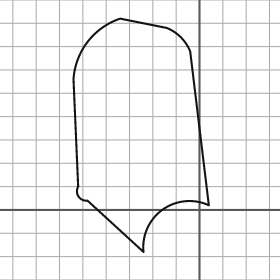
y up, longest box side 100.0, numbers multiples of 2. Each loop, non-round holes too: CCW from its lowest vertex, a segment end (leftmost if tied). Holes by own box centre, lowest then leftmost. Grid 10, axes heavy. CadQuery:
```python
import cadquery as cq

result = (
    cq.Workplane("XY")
    .moveTo(-24.0, -18.0)
    .threePointArc((-16.0, 0.0), (4.0, 2.0))
    .lineTo(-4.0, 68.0)
    .threePointArc((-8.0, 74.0), (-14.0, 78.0))
    .lineTo(-34.0, 82.0)
    .threePointArc((-48.0, 72.0), (-54.0, 56.0))
    .lineTo(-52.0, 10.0)
    .threePointArc((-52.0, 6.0), (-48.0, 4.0))
    .close()
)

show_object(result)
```